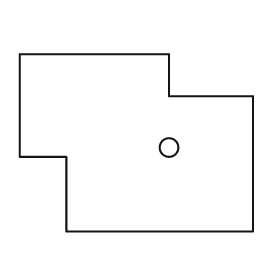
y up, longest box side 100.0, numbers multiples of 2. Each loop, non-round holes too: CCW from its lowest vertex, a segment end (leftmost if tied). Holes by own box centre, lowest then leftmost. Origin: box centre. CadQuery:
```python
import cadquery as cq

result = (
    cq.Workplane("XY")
    .moveTo(-30.0, -38.0)
    .lineTo(50.0, -38.0)
    .lineTo(50.0, 20.0)
    .lineTo(14.0, 20.0)
    .lineTo(14.0, 38.0)
    .lineTo(-50.0, 38.0)
    .lineTo(-50.0, -6.0)
    .lineTo(-30.0, -6.0)
    .close()
    .moveTo(14.0, -2.0)
    .circle(4.0)
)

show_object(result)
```